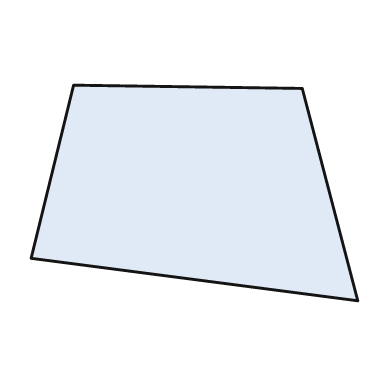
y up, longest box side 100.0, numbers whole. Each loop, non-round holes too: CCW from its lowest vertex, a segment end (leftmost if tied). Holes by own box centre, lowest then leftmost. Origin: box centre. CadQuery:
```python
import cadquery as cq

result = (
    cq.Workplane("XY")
    .moveTo(50.0, -33.0)
    .lineTo(33.0, 32.0)
    .lineTo(-37.0, 33.0)
    .lineTo(-50.0, -20.0)
    .close()
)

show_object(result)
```